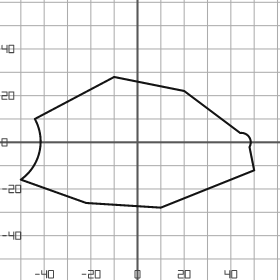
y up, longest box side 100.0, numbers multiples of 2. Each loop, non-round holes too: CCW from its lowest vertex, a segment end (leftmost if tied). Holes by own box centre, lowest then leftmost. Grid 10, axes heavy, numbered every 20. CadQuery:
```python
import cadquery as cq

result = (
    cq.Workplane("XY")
    .moveTo(10.0, -28.0)
    .lineTo(50.0, -12.0)
    .lineTo(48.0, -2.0)
    .threePointArc((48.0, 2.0), (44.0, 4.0))
    .lineTo(20.0, 22.0)
    .lineTo(-10.0, 28.0)
    .lineTo(-44.0, 10.0)
    .threePointArc((-42.0, -4.0), (-50.0, -16.0))
    .lineTo(-22.0, -26.0)
    .close()
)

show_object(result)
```